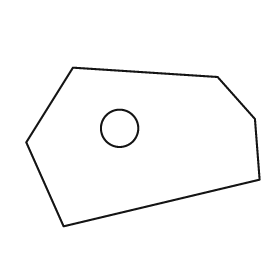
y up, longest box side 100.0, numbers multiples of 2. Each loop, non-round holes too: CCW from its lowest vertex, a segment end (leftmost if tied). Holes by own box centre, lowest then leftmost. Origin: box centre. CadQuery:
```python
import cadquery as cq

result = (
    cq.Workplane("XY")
    .moveTo(-34.0, -34.0)
    .lineTo(50.0, -14.0)
    .lineTo(48.0, 12.0)
    .lineTo(32.0, 30.0)
    .lineTo(-30.0, 34.0)
    .lineTo(-50.0, 2.0)
    .close()
    .moveTo(-10.0, 8.0)
    .circle(8.0)
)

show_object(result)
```